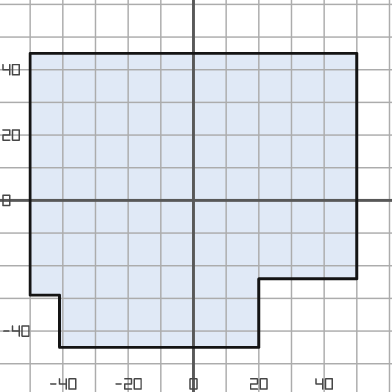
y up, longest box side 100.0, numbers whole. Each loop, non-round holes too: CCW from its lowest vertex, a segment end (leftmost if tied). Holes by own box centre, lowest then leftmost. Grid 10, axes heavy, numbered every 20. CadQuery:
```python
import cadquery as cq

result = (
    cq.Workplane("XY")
    .moveTo(-41.0, -45.0)
    .lineTo(20.0, -45.0)
    .lineTo(20.0, -24.0)
    .lineTo(50.0, -24.0)
    .lineTo(50.0, 45.0)
    .lineTo(-50.0, 45.0)
    .lineTo(-50.0, -29.0)
    .lineTo(-41.0, -29.0)
    .close()
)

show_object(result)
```